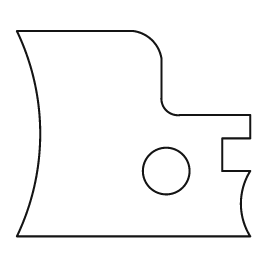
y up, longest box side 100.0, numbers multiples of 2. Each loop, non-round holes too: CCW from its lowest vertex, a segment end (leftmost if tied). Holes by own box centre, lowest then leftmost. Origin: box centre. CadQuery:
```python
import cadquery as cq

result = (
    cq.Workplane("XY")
    .moveTo(-50.0, -44.0)
    .lineTo(50.0, -44.0)
    .threePointArc((46.0, -30.0), (50.0, -16.0))
    .lineTo(38.0, -16.0)
    .lineTo(38.0, -2.0)
    .lineTo(50.0, -2.0)
    .lineTo(50.0, 8.0)
    .lineTo(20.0, 8.0)
    .threePointArc((14.0, 10.0), (12.0, 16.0))
    .lineTo(12.0, 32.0)
    .threePointArc((8.0, 40.0), (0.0, 44.0))
    .lineTo(-50.0, 44.0)
    .threePointArc((-40.0, 0.0), (-50.0, -44.0))
    .close()
    .moveTo(14.0, -16.0)
    .circle(10.0)
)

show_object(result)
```